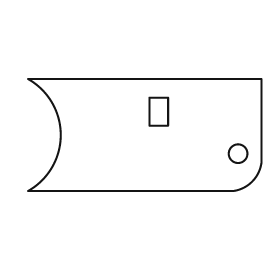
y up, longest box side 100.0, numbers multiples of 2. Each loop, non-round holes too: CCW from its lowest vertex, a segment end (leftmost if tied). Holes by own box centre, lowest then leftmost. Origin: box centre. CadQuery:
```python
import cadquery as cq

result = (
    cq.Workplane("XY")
    .moveTo(-50.0, -24.0)
    .lineTo(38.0, -24.0)
    .threePointArc((46.0, -20.0), (50.0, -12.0))
    .lineTo(50.0, 24.0)
    .lineTo(-50.0, 24.0)
    .threePointArc((-36.0, 0.0), (-50.0, -24.0))
    .close()
    .moveTo(40.0, -8.0)
    .circle(4.0)
    .moveTo(2.0, 4.0)
    .lineTo(10.0, 4.0)
    .lineTo(10.0, 16.0)
    .lineTo(2.0, 16.0)
    .close()
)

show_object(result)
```